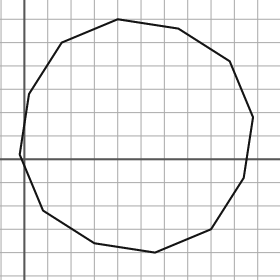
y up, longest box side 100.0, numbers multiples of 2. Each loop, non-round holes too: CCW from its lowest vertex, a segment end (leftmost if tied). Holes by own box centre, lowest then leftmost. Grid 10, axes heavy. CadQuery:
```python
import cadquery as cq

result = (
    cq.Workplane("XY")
    .moveTo(56.0, -40.0)
    .lineTo(80.0, -30.0)
    .lineTo(94.0, -8.0)
    .lineTo(98.0, 18.0)
    .lineTo(88.0, 42.0)
    .lineTo(66.0, 56.0)
    .lineTo(40.0, 60.0)
    .lineTo(16.0, 50.0)
    .lineTo(2.0, 28.0)
    .lineTo(-2.0, 2.0)
    .lineTo(8.0, -22.0)
    .lineTo(30.0, -36.0)
    .close()
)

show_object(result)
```